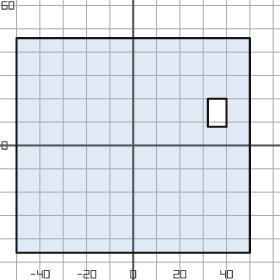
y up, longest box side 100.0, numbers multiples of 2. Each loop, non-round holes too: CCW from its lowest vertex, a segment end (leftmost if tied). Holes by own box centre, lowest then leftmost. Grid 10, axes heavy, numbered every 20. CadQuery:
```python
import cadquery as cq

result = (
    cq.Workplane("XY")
    .moveTo(-50.0, -46.0)
    .lineTo(50.0, -46.0)
    .lineTo(50.0, 46.0)
    .lineTo(-50.0, 46.0)
    .close()
    .moveTo(32.0, 8.0)
    .lineTo(40.0, 8.0)
    .lineTo(40.0, 20.0)
    .lineTo(32.0, 20.0)
    .close()
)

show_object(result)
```